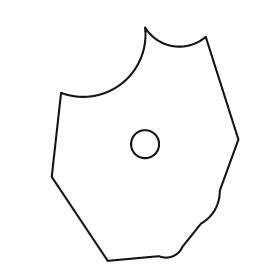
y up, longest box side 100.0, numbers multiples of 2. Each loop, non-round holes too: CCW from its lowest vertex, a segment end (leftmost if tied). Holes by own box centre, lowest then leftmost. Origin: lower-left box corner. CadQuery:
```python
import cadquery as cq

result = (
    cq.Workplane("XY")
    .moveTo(24.0, 0.0)
    .lineTo(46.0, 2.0)
    .threePointArc((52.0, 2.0), (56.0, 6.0))
    .lineTo(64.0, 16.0)
    .threePointArc((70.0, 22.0), (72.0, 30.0))
    .lineTo(80.0, 52.0)
    .lineTo(66.0, 96.0)
    .threePointArc((52.0, 92.0), (40.0, 100.0))
    .threePointArc((30.0, 76.0), (4.0, 72.0))
    .lineTo(0.0, 36.0)
    .close()
    .moveTo(40.0, 50.0)
    .circle(6.0)
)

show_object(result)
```